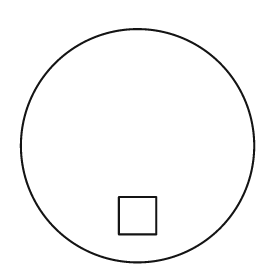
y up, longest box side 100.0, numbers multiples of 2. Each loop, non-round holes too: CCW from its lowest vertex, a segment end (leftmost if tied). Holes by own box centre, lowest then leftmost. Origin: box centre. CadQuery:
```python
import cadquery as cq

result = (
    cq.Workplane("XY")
    .moveTo(0.0, 0.0)
    .circle(50.0)
    .moveTo(-8.0, -38.0)
    .lineTo(8.0, -38.0)
    .lineTo(8.0, -22.0)
    .lineTo(-8.0, -22.0)
    .close()
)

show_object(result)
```